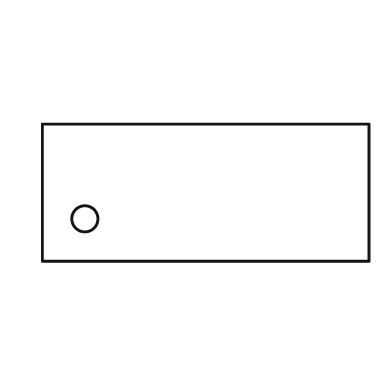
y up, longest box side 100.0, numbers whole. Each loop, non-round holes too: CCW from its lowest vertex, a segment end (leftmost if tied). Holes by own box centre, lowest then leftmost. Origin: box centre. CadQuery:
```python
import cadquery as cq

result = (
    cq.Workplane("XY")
    .moveTo(-50.0, -21.0)
    .lineTo(50.0, -21.0)
    .lineTo(50.0, 21.0)
    .lineTo(-50.0, 21.0)
    .close()
    .moveTo(-37.0, -8.0)
    .circle(4.0)
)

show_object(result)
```